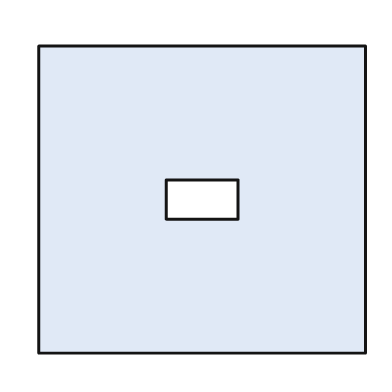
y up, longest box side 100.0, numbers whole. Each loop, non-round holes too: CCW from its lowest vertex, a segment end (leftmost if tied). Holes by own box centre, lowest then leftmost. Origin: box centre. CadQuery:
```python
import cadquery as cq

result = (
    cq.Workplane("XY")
    .moveTo(-50.0, -47.0)
    .lineTo(50.0, -47.0)
    .lineTo(50.0, 47.0)
    .lineTo(-50.0, 47.0)
    .close()
    .moveTo(-11.0, -6.0)
    .lineTo(11.0, -6.0)
    .lineTo(11.0, 6.0)
    .lineTo(-11.0, 6.0)
    .close()
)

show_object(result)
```